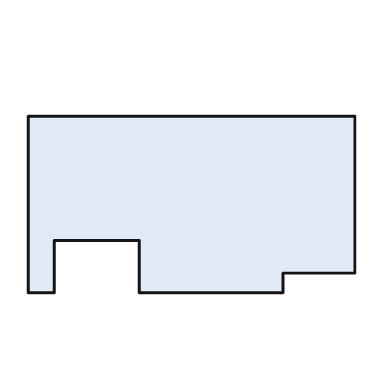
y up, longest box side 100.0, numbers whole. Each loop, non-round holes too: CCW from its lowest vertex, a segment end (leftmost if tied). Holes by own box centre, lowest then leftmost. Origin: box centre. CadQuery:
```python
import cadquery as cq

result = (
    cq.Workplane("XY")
    .moveTo(-50.0, -27.0)
    .lineTo(-42.0, -27.0)
    .lineTo(-42.0, -11.0)
    .lineTo(-16.0, -11.0)
    .lineTo(-16.0, -27.0)
    .lineTo(28.0, -27.0)
    .lineTo(28.0, -21.0)
    .lineTo(50.0, -21.0)
    .lineTo(50.0, 27.0)
    .lineTo(-50.0, 27.0)
    .close()
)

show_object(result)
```